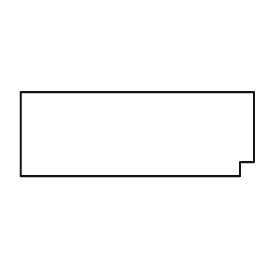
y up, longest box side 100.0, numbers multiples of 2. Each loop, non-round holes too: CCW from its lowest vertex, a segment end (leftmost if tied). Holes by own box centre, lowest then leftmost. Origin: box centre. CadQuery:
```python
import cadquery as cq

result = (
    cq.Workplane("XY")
    .moveTo(-50.0, -18.0)
    .lineTo(44.0, -18.0)
    .lineTo(44.0, -12.0)
    .lineTo(50.0, -12.0)
    .lineTo(50.0, 18.0)
    .lineTo(-50.0, 18.0)
    .close()
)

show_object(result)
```